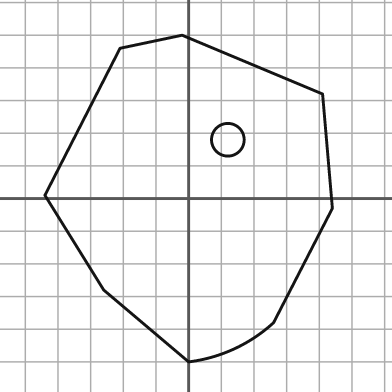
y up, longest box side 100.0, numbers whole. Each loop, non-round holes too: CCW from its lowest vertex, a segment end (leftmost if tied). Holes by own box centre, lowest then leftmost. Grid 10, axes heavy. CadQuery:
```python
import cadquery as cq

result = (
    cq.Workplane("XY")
    .moveTo(0.0, -50.0)
    .threePointArc((14.0, -46.0), (26.0, -38.0))
    .lineTo(44.0, -3.0)
    .lineTo(41.0, 32.0)
    .lineTo(-2.0, 50.0)
    .lineTo(-21.0, 46.0)
    .lineTo(-44.0, 1.0)
    .lineTo(-26.0, -28.0)
    .close()
    .moveTo(12.0, 18.0)
    .circle(5.0)
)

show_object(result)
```